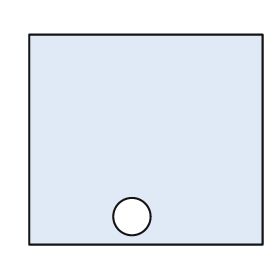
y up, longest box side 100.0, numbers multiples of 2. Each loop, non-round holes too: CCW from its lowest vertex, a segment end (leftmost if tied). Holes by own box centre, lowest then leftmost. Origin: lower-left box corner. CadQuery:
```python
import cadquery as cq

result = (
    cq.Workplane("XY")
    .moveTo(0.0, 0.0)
    .lineTo(100.0, 0.0)
    .lineTo(100.0, 90.0)
    .lineTo(0.0, 90.0)
    .close()
    .moveTo(44.0, 12.0)
    .circle(8.0)
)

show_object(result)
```